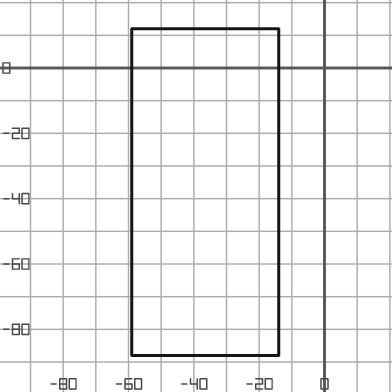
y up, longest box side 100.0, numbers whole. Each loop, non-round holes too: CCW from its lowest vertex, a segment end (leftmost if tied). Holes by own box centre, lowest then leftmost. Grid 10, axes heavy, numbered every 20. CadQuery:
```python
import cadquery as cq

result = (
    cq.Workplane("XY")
    .moveTo(-59.0, -88.0)
    .lineTo(-14.0, -88.0)
    .lineTo(-14.0, 12.0)
    .lineTo(-59.0, 12.0)
    .close()
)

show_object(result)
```